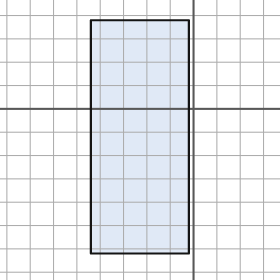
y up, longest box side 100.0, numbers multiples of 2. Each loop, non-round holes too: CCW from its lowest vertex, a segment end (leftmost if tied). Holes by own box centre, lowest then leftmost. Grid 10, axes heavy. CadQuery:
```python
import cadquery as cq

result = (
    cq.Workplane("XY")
    .moveTo(-44.0, -62.0)
    .lineTo(-2.0, -62.0)
    .lineTo(-2.0, 38.0)
    .lineTo(-44.0, 38.0)
    .close()
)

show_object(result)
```